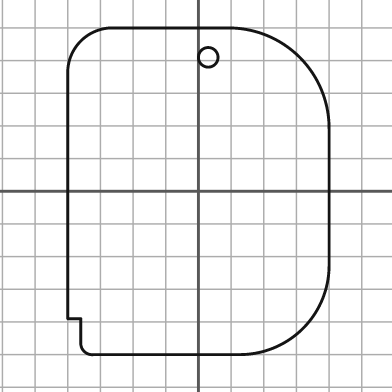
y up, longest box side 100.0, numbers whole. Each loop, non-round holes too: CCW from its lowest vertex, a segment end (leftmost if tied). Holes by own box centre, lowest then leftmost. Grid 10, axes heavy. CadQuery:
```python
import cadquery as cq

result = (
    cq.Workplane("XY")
    .moveTo(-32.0, -50.0)
    .lineTo(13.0, -50.0)
    .threePointArc((32.0, -42.0), (40.0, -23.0))
    .lineTo(40.0, 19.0)
    .threePointArc((31.0, 41.0), (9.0, 50.0))
    .lineTo(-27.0, 50.0)
    .threePointArc((-36.0, 46.0), (-40.0, 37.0))
    .lineTo(-40.0, -39.0)
    .lineTo(-36.0, -39.0)
    .lineTo(-36.0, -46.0)
    .threePointArc((-35.0, -49.0), (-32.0, -50.0))
    .close()
    .moveTo(3.0, 41.0)
    .circle(3.0)
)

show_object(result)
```